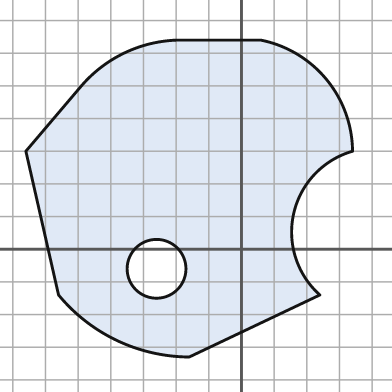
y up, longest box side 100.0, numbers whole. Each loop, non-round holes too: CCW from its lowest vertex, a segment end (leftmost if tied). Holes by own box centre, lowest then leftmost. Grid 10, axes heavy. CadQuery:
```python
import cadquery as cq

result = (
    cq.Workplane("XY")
    .moveTo(-16.0, -33.0)
    .lineTo(24.0, -14.0)
    .threePointArc((16.0, 11.0), (34.0, 30.0))
    .threePointArc((26.0, 52.0), (6.0, 64.0))
    .lineTo(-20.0, 64.0)
    .threePointArc((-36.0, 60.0), (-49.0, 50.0))
    .lineTo(-66.0, 30.0)
    .lineTo(-56.0, -14.0)
    .threePointArc((-38.0, -28.0), (-16.0, -33.0))
    .close()
    .moveTo(-26.0, -6.0)
    .circle(9.0)
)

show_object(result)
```